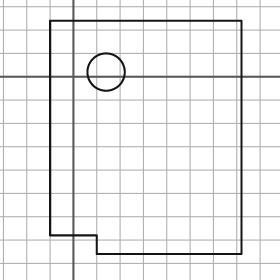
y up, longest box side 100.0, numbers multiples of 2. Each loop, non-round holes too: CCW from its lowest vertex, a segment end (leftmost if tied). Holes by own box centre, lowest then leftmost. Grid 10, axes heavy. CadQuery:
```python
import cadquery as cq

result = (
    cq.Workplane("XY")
    .moveTo(10.0, -76.0)
    .lineTo(72.0, -76.0)
    .lineTo(72.0, 24.0)
    .lineTo(-10.0, 24.0)
    .lineTo(-10.0, -68.0)
    .lineTo(10.0, -68.0)
    .close()
    .moveTo(14.0, 2.0)
    .circle(8.0)
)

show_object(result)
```